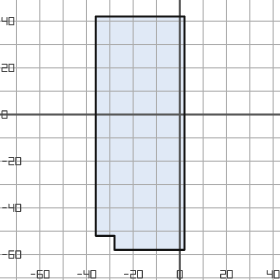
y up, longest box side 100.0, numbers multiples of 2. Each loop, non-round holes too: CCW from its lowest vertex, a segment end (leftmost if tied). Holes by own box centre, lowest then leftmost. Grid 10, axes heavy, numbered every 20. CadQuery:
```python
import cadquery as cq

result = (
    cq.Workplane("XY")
    .moveTo(-28.0, -58.0)
    .lineTo(2.0, -58.0)
    .lineTo(2.0, 42.0)
    .lineTo(-36.0, 42.0)
    .lineTo(-36.0, -52.0)
    .lineTo(-28.0, -52.0)
    .close()
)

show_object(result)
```